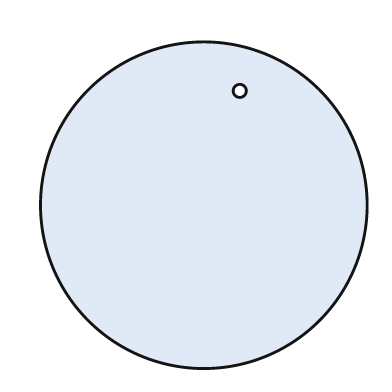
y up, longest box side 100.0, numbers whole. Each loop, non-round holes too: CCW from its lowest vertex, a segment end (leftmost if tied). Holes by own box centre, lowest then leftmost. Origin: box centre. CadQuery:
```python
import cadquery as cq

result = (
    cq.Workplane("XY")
    .moveTo(0.0, 0.0)
    .circle(50.0)
    .moveTo(11.0, 35.0)
    .circle(2.0)
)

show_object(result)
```